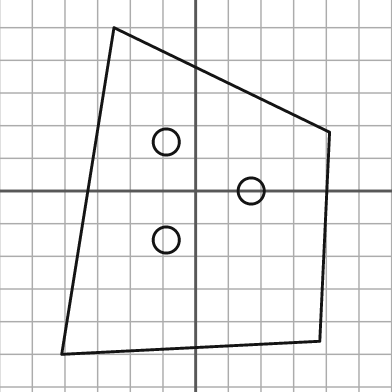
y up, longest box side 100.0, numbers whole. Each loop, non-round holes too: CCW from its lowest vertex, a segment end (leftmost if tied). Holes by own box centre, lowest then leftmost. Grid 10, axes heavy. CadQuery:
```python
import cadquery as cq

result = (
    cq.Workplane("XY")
    .moveTo(-41.0, -50.0)
    .lineTo(38.0, -46.0)
    .lineTo(41.0, 18.0)
    .lineTo(-25.0, 50.0)
    .close()
    .moveTo(-9.0, -15.0)
    .circle(4.0)
    .moveTo(17.0, 0.0)
    .circle(4.0)
    .moveTo(-9.0, 15.0)
    .circle(4.0)
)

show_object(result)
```